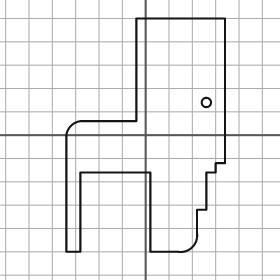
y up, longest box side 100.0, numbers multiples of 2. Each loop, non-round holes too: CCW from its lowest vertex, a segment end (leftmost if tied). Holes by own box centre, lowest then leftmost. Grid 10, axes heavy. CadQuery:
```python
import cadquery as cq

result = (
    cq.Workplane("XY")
    .moveTo(-34.0, -50.0)
    .lineTo(-28.0, -50.0)
    .lineTo(-28.0, -16.0)
    .lineTo(2.0, -16.0)
    .lineTo(2.0, -50.0)
    .lineTo(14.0, -50.0)
    .threePointArc((20.0, -48.0), (22.0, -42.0))
    .lineTo(22.0, -32.0)
    .lineTo(26.0, -32.0)
    .lineTo(26.0, -16.0)
    .lineTo(30.0, -16.0)
    .lineTo(30.0, -12.0)
    .lineTo(34.0, -12.0)
    .lineTo(34.0, 50.0)
    .lineTo(-4.0, 50.0)
    .lineTo(-4.0, 6.0)
    .lineTo(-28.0, 6.0)
    .threePointArc((-32.0, 4.0), (-34.0, 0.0))
    .close()
    .moveTo(26.0, 14.0)
    .circle(2.0)
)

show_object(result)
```